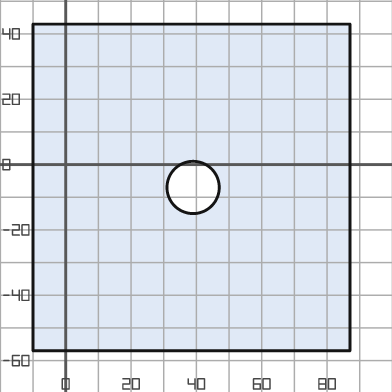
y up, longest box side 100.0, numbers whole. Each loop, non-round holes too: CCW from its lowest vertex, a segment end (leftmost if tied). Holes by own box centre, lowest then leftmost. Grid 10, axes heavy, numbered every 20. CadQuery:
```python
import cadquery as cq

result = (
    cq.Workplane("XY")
    .moveTo(-10.0, -57.0)
    .lineTo(87.0, -57.0)
    .lineTo(87.0, 43.0)
    .lineTo(-10.0, 43.0)
    .close()
    .moveTo(39.0, -7.0)
    .circle(8.0)
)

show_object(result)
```